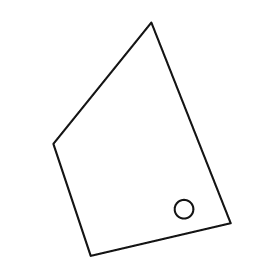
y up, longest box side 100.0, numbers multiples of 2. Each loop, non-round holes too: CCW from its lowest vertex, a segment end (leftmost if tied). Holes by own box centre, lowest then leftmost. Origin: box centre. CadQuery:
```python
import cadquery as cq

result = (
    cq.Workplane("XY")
    .moveTo(-22.0, -50.0)
    .lineTo(38.0, -36.0)
    .lineTo(4.0, 50.0)
    .lineTo(-38.0, -2.0)
    .close()
    .moveTo(18.0, -30.0)
    .circle(4.0)
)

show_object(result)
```